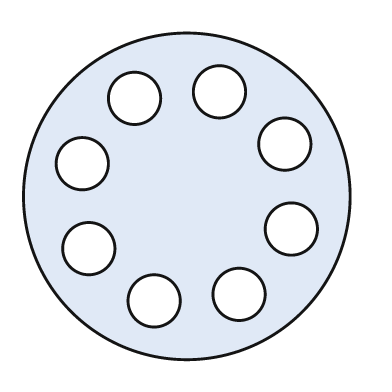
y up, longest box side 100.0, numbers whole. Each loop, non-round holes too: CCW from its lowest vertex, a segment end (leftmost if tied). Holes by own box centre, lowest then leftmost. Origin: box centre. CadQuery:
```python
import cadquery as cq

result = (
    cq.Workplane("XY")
    .moveTo(0.0, 0.0)
    .circle(50.0)
    .moveTo(-10.0, -32.0)
    .circle(8.0)
    .moveTo(16.0, -30.0)
    .circle(8.0)
    .moveTo(-30.0, -16.0)
    .circle(8.0)
    .moveTo(32.0, -10.0)
    .circle(8.0)
    .moveTo(-32.0, 10.0)
    .circle(8.0)
    .moveTo(30.0, 16.0)
    .circle(8.0)
    .moveTo(-16.0, 30.0)
    .circle(8.0)
    .moveTo(10.0, 32.0)
    .circle(8.0)
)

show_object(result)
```